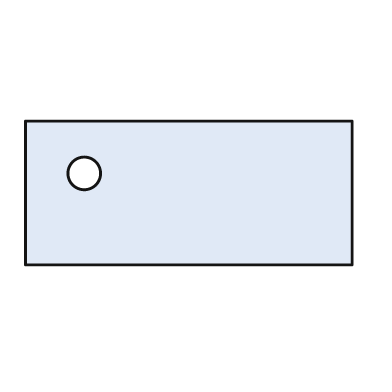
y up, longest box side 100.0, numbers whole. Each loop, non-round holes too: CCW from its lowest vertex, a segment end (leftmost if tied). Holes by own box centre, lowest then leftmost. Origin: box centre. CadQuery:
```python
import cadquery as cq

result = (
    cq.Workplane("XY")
    .moveTo(-50.0, -22.0)
    .lineTo(50.0, -22.0)
    .lineTo(50.0, 22.0)
    .lineTo(-50.0, 22.0)
    .close()
    .moveTo(-32.0, 6.0)
    .circle(5.0)
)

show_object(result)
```